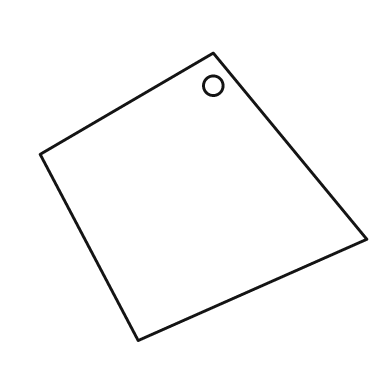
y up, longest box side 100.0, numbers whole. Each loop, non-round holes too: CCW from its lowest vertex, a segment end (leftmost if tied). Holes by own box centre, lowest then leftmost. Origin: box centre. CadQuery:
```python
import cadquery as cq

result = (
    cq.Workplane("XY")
    .moveTo(-20.0, -44.0)
    .lineTo(50.0, -13.0)
    .lineTo(3.0, 44.0)
    .lineTo(-50.0, 13.0)
    .close()
    .moveTo(3.0, 34.0)
    .circle(3.0)
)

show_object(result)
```